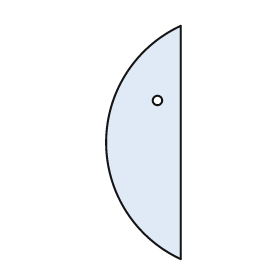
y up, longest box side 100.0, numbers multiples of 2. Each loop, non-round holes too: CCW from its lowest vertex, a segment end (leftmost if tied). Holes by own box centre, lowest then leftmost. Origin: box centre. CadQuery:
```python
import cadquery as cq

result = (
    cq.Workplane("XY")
    .moveTo(16.0, -50.0)
    .lineTo(16.0, 50.0)
    .threePointArc((-16.0, 0.0), (16.0, -50.0))
    .close()
    .moveTo(6.0, 18.0)
    .circle(2.0)
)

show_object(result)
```